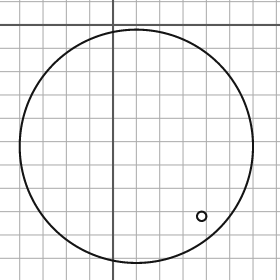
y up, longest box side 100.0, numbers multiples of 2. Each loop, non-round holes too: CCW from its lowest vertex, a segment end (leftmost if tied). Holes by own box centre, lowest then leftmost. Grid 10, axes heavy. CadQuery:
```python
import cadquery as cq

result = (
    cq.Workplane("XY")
    .moveTo(10.0, -52.0)
    .circle(50.0)
    .moveTo(38.0, -82.0)
    .circle(2.0)
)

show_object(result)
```